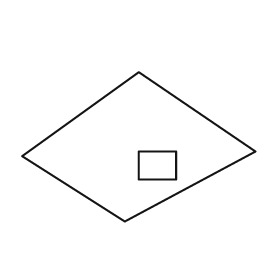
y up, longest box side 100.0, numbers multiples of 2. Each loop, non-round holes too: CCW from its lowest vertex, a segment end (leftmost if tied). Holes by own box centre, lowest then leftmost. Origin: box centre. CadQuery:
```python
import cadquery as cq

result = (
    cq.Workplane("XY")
    .moveTo(-6.0, -32.0)
    .lineTo(50.0, -2.0)
    .lineTo(0.0, 32.0)
    .lineTo(-50.0, -4.0)
    .close()
    .moveTo(0.0, -14.0)
    .lineTo(16.0, -14.0)
    .lineTo(16.0, -2.0)
    .lineTo(0.0, -2.0)
    .close()
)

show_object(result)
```